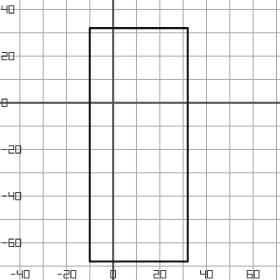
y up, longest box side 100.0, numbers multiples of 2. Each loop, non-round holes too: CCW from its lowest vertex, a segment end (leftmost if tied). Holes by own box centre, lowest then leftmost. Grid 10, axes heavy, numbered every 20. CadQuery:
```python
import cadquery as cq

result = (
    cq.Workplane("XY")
    .moveTo(-10.0, -68.0)
    .lineTo(32.0, -68.0)
    .lineTo(32.0, 32.0)
    .lineTo(-10.0, 32.0)
    .close()
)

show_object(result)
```